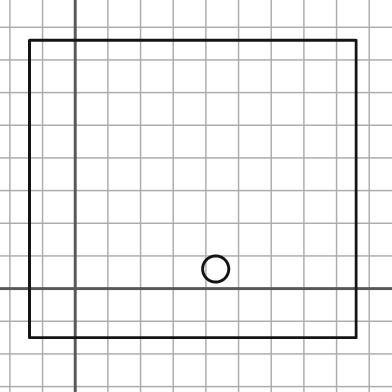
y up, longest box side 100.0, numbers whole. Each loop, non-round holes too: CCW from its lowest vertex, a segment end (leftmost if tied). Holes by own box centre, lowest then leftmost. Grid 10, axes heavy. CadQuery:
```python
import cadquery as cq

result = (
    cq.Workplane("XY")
    .moveTo(-14.0, -15.0)
    .lineTo(86.0, -15.0)
    .lineTo(86.0, 76.0)
    .lineTo(-14.0, 76.0)
    .close()
    .moveTo(43.0, 6.0)
    .circle(4.0)
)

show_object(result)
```